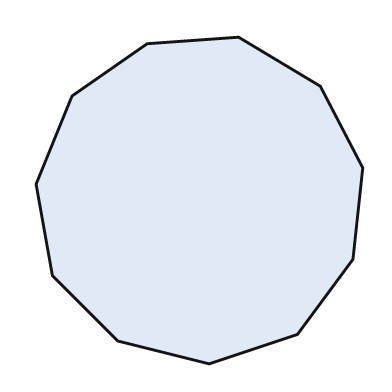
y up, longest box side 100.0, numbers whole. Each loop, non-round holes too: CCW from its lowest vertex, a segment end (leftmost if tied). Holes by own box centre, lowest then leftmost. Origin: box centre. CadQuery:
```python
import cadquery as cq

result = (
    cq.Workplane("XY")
    .moveTo(3.0, -50.0)
    .lineTo(30.0, -41.0)
    .lineTo(47.0, -18.0)
    .lineTo(50.0, 10.0)
    .lineTo(37.0, 35.0)
    .lineTo(12.0, 50.0)
    .lineTo(-16.0, 48.0)
    .lineTo(-39.0, 32.0)
    .lineTo(-50.0, 5.0)
    .lineTo(-45.0, -23.0)
    .lineTo(-25.0, -43.0)
    .close()
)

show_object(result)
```